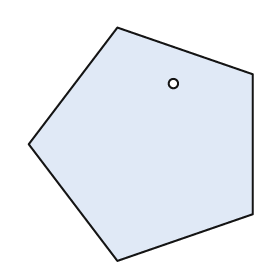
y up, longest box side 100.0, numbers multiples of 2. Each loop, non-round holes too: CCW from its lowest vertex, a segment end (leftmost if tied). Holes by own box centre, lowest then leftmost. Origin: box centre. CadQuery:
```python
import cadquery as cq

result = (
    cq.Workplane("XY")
    .moveTo(-10.0, -50.0)
    .lineTo(48.0, -30.0)
    .lineTo(48.0, 30.0)
    .lineTo(-10.0, 50.0)
    .lineTo(-48.0, 0.0)
    .close()
    .moveTo(14.0, 26.0)
    .circle(2.0)
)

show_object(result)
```